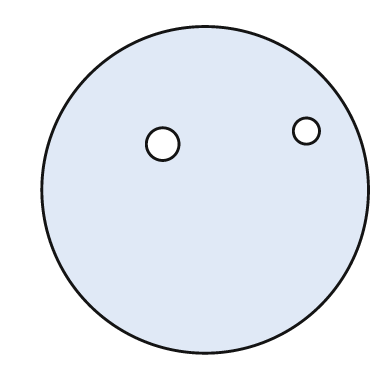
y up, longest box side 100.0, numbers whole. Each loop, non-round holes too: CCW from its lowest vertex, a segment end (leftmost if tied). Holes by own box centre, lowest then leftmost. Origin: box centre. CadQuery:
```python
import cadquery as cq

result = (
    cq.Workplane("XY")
    .moveTo(0.0, 0.0)
    .circle(50.0)
    .moveTo(-13.0, 14.0)
    .circle(5.0)
    .moveTo(31.0, 18.0)
    .circle(4.0)
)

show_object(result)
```